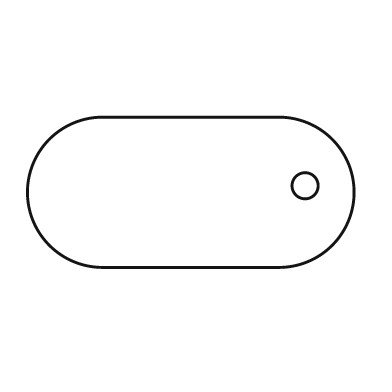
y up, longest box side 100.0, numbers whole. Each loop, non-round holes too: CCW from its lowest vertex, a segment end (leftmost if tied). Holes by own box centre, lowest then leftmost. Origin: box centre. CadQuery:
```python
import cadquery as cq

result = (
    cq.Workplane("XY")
    .moveTo(-27.0, -23.0)
    .lineTo(27.0, -23.0)
    .threePointArc((50.0, 0.0), (27.0, 23.0))
    .lineTo(-27.0, 23.0)
    .threePointArc((-50.0, 0.0), (-27.0, -23.0))
    .close()
    .moveTo(35.0, 2.0)
    .circle(4.0)
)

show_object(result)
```